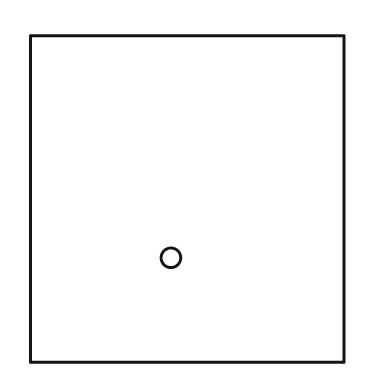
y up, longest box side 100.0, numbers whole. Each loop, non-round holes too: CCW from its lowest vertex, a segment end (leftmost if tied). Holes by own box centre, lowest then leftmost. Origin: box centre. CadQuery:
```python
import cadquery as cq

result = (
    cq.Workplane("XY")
    .moveTo(-48.0, -50.0)
    .lineTo(48.0, -50.0)
    .lineTo(48.0, 50.0)
    .lineTo(-48.0, 50.0)
    .close()
    .moveTo(-5.0, -18.0)
    .circle(3.0)
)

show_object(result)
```